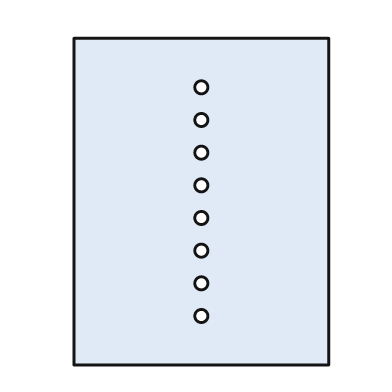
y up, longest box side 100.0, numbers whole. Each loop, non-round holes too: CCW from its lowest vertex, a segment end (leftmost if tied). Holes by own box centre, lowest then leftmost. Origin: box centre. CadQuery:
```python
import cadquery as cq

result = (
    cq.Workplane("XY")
    .moveTo(-39.0, -50.0)
    .lineTo(39.0, -50.0)
    .lineTo(39.0, 50.0)
    .lineTo(-39.0, 50.0)
    .close()
    .moveTo(0.0, -35.0)
    .circle(2.0)
    .moveTo(0.0, -25.0)
    .circle(2.0)
    .moveTo(0.0, -15.0)
    .circle(2.0)
    .moveTo(0.0, -5.0)
    .circle(2.0)
    .moveTo(0.0, 5.0)
    .circle(2.0)
    .moveTo(0.0, 15.0)
    .circle(2.0)
    .moveTo(0.0, 25.0)
    .circle(2.0)
    .moveTo(0.0, 35.0)
    .circle(2.0)
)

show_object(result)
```